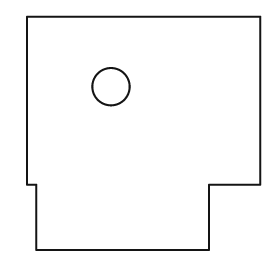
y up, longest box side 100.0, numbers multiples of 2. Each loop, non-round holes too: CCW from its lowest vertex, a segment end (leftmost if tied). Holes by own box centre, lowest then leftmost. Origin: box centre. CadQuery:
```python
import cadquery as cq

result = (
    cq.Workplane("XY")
    .moveTo(-46.0, -50.0)
    .lineTo(28.0, -50.0)
    .lineTo(28.0, -22.0)
    .lineTo(50.0, -22.0)
    .lineTo(50.0, 50.0)
    .lineTo(-50.0, 50.0)
    .lineTo(-50.0, -22.0)
    .lineTo(-46.0, -22.0)
    .close()
    .moveTo(-14.0, 20.0)
    .circle(8.0)
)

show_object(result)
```